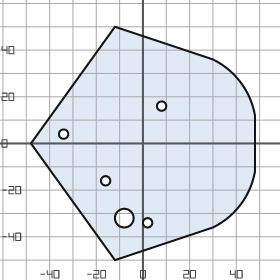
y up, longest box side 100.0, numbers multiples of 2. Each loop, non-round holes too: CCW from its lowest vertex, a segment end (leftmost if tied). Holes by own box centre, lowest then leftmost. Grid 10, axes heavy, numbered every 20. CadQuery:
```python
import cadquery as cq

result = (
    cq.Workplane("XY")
    .moveTo(-12.0, -50.0)
    .lineTo(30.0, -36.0)
    .threePointArc((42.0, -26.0), (48.0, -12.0))
    .lineTo(48.0, 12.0)
    .threePointArc((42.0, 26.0), (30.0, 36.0))
    .lineTo(-12.0, 50.0)
    .lineTo(-48.0, 0.0)
    .close()
    .moveTo(2.0, -34.0)
    .circle(2.0)
    .moveTo(-8.0, -32.0)
    .circle(4.0)
    .moveTo(-16.0, -16.0)
    .circle(2.0)
    .moveTo(-34.0, 4.0)
    .circle(2.0)
    .moveTo(8.0, 16.0)
    .circle(2.0)
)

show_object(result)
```